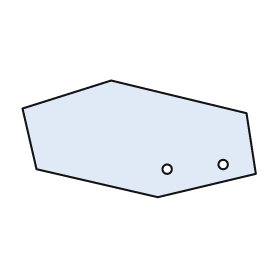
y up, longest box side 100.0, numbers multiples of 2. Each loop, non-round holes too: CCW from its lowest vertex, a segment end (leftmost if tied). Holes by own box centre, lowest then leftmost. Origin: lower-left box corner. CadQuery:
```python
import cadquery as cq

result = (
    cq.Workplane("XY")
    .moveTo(58.0, 0.0)
    .lineTo(100.0, 10.0)
    .lineTo(96.0, 36.0)
    .lineTo(38.0, 50.0)
    .lineTo(0.0, 38.0)
    .lineTo(6.0, 12.0)
    .close()
    .moveTo(62.0, 12.0)
    .circle(2.0)
    .moveTo(86.0, 14.0)
    .circle(2.0)
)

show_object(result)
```